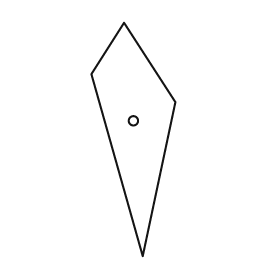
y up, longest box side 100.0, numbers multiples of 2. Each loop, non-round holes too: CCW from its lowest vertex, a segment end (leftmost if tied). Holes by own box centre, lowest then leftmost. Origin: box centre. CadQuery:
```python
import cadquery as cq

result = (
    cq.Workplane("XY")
    .moveTo(4.0, -50.0)
    .lineTo(18.0, 16.0)
    .lineTo(-4.0, 50.0)
    .lineTo(-18.0, 28.0)
    .close()
    .moveTo(0.0, 8.0)
    .circle(2.0)
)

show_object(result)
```